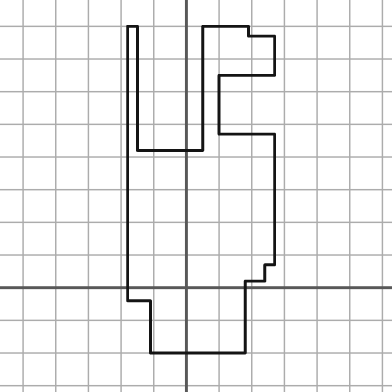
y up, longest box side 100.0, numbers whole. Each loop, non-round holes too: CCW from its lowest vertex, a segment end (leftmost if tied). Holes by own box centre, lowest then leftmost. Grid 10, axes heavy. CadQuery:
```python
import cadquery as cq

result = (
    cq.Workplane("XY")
    .moveTo(-11.0, -20.0)
    .lineTo(18.0, -20.0)
    .lineTo(18.0, 2.0)
    .lineTo(24.0, 2.0)
    .lineTo(24.0, 7.0)
    .lineTo(27.0, 7.0)
    .lineTo(27.0, 47.0)
    .lineTo(10.0, 47.0)
    .lineTo(10.0, 65.0)
    .lineTo(27.0, 65.0)
    .lineTo(27.0, 77.0)
    .lineTo(19.0, 77.0)
    .lineTo(19.0, 80.0)
    .lineTo(5.0, 80.0)
    .lineTo(5.0, 42.0)
    .lineTo(-15.0, 42.0)
    .lineTo(-15.0, 80.0)
    .lineTo(-18.0, 80.0)
    .lineTo(-18.0, -4.0)
    .lineTo(-11.0, -4.0)
    .close()
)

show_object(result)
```